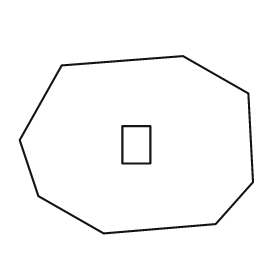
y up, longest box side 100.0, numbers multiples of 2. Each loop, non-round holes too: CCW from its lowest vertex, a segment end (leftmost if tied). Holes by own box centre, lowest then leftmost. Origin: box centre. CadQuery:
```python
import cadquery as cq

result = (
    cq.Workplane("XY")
    .moveTo(-14.0, -38.0)
    .lineTo(34.0, -34.0)
    .lineTo(50.0, -16.0)
    .lineTo(48.0, 22.0)
    .lineTo(20.0, 38.0)
    .lineTo(-32.0, 34.0)
    .lineTo(-50.0, 2.0)
    .lineTo(-42.0, -22.0)
    .close()
    .moveTo(-6.0, -8.0)
    .lineTo(6.0, -8.0)
    .lineTo(6.0, 8.0)
    .lineTo(-6.0, 8.0)
    .close()
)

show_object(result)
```